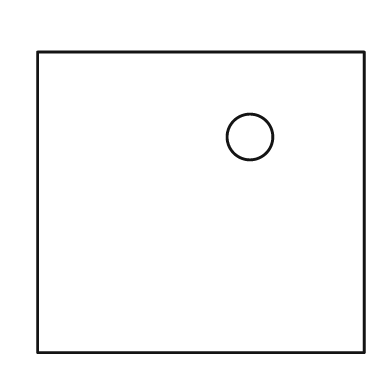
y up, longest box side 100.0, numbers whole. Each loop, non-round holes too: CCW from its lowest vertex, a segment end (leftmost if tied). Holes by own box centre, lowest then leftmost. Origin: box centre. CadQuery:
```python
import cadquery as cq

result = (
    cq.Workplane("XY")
    .moveTo(-50.0, -46.0)
    .lineTo(50.0, -46.0)
    .lineTo(50.0, 46.0)
    .lineTo(-50.0, 46.0)
    .close()
    .moveTo(15.0, 20.0)
    .circle(7.0)
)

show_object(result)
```